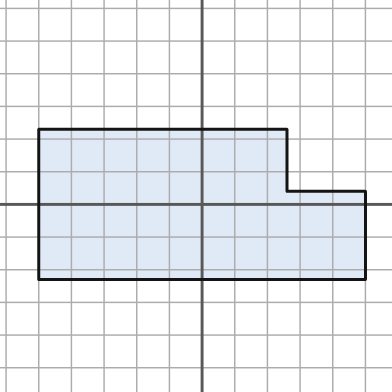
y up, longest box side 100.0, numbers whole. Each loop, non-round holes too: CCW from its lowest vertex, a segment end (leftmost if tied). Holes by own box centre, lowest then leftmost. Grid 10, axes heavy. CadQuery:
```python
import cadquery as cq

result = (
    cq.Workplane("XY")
    .moveTo(-50.0, -23.0)
    .lineTo(50.0, -23.0)
    .lineTo(50.0, 4.0)
    .lineTo(26.0, 4.0)
    .lineTo(26.0, 23.0)
    .lineTo(-50.0, 23.0)
    .close()
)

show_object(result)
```